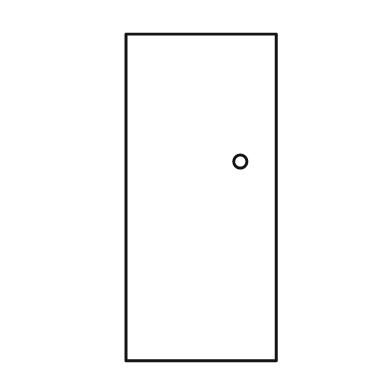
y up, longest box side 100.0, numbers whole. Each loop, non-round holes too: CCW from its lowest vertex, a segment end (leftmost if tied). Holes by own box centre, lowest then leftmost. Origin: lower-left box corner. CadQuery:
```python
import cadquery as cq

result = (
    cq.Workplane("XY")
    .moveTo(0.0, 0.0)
    .lineTo(46.0, 0.0)
    .lineTo(46.0, 100.0)
    .lineTo(0.0, 100.0)
    .close()
    .moveTo(35.0, 61.0)
    .circle(2.0)
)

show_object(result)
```